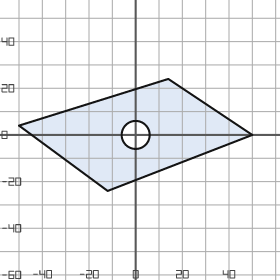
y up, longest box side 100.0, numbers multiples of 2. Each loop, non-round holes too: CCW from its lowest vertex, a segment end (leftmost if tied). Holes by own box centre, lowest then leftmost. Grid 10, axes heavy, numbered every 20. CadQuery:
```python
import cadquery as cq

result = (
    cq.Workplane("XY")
    .moveTo(-12.0, -24.0)
    .lineTo(50.0, 0.0)
    .lineTo(14.0, 24.0)
    .lineTo(-50.0, 4.0)
    .close()
    .moveTo(0.0, 0.0)
    .circle(6.0)
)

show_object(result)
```